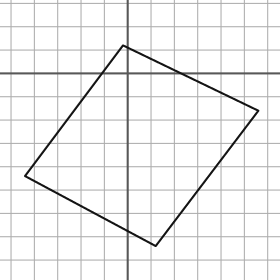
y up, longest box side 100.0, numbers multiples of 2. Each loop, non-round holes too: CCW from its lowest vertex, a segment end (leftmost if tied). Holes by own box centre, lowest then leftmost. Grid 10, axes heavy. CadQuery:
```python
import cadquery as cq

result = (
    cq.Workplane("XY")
    .moveTo(12.0, -74.0)
    .lineTo(56.0, -16.0)
    .lineTo(-2.0, 12.0)
    .lineTo(-44.0, -44.0)
    .close()
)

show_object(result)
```